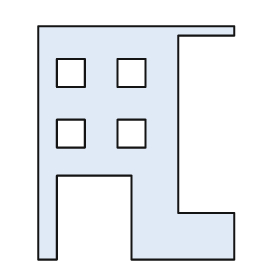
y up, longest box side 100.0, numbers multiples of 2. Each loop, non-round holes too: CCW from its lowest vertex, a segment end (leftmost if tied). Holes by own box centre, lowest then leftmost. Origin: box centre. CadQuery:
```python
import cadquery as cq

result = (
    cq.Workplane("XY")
    .moveTo(-42.0, -50.0)
    .lineTo(-34.0, -50.0)
    .lineTo(-34.0, -14.0)
    .lineTo(-2.0, -14.0)
    .lineTo(-2.0, -50.0)
    .lineTo(42.0, -50.0)
    .lineTo(42.0, -30.0)
    .lineTo(18.0, -30.0)
    .lineTo(18.0, 46.0)
    .lineTo(42.0, 46.0)
    .lineTo(42.0, 50.0)
    .lineTo(-42.0, 50.0)
    .close()
    .moveTo(-34.0, -2.0)
    .lineTo(-22.0, -2.0)
    .lineTo(-22.0, 10.0)
    .lineTo(-34.0, 10.0)
    .close()
    .moveTo(-8.0, -2.0)
    .lineTo(4.0, -2.0)
    .lineTo(4.0, 10.0)
    .lineTo(-8.0, 10.0)
    .close()
    .moveTo(-34.0, 24.0)
    .lineTo(-22.0, 24.0)
    .lineTo(-22.0, 36.0)
    .lineTo(-34.0, 36.0)
    .close()
    .moveTo(-8.0, 24.0)
    .lineTo(4.0, 24.0)
    .lineTo(4.0, 36.0)
    .lineTo(-8.0, 36.0)
    .close()
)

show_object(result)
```